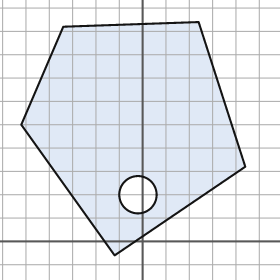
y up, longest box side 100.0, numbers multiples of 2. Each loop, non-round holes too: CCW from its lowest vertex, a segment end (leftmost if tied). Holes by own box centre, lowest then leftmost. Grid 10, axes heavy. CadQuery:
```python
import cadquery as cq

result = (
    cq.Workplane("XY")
    .moveTo(-12.0, -6.0)
    .lineTo(44.0, 32.0)
    .lineTo(24.0, 94.0)
    .lineTo(-34.0, 92.0)
    .lineTo(-52.0, 50.0)
    .close()
    .moveTo(-2.0, 20.0)
    .circle(8.0)
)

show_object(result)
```